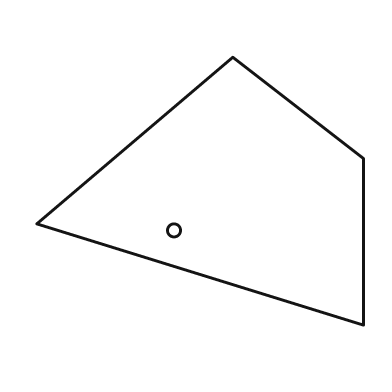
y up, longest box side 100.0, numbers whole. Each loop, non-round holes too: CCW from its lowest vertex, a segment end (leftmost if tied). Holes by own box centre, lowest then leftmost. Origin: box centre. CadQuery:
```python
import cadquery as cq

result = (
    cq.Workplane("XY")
    .moveTo(50.0, -41.0)
    .lineTo(50.0, 10.0)
    .lineTo(10.0, 41.0)
    .lineTo(-50.0, -10.0)
    .close()
    .moveTo(-8.0, -12.0)
    .circle(2.0)
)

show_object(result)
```